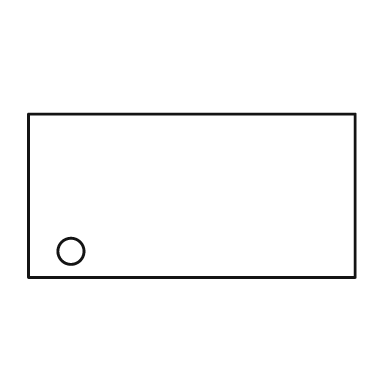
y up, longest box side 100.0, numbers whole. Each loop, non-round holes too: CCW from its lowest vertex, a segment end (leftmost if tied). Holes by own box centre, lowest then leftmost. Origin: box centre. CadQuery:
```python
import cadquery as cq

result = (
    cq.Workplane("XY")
    .moveTo(-50.0, -25.0)
    .lineTo(50.0, -25.0)
    .lineTo(50.0, 25.0)
    .lineTo(-50.0, 25.0)
    .close()
    .moveTo(-37.0, -17.0)
    .circle(4.0)
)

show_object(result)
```